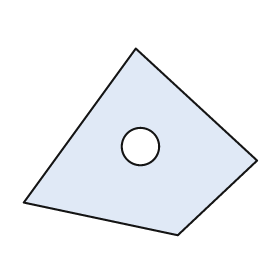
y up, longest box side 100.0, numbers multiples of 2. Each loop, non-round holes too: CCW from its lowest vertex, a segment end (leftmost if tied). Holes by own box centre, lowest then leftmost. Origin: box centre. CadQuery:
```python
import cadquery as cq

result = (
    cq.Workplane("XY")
    .moveTo(16.0, -40.0)
    .lineTo(50.0, -8.0)
    .lineTo(-2.0, 40.0)
    .lineTo(-50.0, -26.0)
    .close()
    .moveTo(0.0, -2.0)
    .circle(8.0)
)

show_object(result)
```